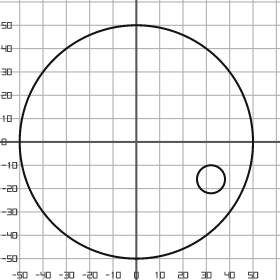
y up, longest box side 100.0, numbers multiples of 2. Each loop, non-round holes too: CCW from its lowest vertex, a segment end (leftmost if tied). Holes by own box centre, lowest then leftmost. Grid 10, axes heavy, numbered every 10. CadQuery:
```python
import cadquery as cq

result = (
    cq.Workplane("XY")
    .moveTo(0.0, 0.0)
    .circle(50.0)
    .moveTo(32.0, -16.0)
    .circle(6.0)
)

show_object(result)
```